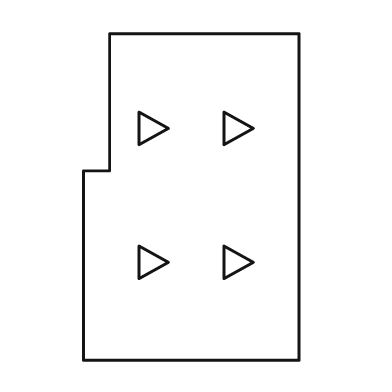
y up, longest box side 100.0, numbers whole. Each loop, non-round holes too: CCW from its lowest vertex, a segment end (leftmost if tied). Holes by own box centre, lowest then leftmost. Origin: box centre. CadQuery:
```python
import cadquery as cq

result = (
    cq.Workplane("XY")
    .moveTo(-33.0, -50.0)
    .lineTo(33.0, -50.0)
    .lineTo(33.0, 50.0)
    .lineTo(-25.0, 50.0)
    .lineTo(-25.0, 8.0)
    .lineTo(-33.0, 8.0)
    .close()
    .moveTo(-16.0, -25.0)
    .lineTo(-7.0, -20.0)
    .lineTo(-16.0, -15.0)
    .close()
    .moveTo(10.0, -25.0)
    .lineTo(19.0, -20.0)
    .lineTo(10.0, -15.0)
    .close()
    .moveTo(-16.0, 16.0)
    .lineTo(-7.0, 21.0)
    .lineTo(-16.0, 26.0)
    .close()
    .moveTo(10.0, 16.0)
    .lineTo(19.0, 21.0)
    .lineTo(10.0, 26.0)
    .close()
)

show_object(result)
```